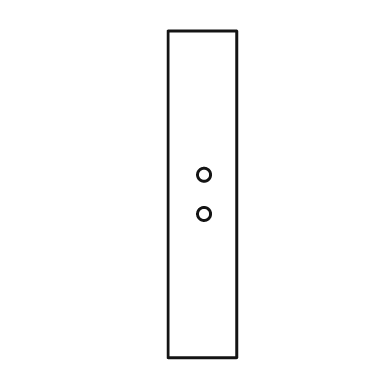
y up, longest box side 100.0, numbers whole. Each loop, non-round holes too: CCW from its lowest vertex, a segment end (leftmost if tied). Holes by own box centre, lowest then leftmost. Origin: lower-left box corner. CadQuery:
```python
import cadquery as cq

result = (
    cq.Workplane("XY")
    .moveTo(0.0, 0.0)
    .lineTo(21.0, 0.0)
    .lineTo(21.0, 100.0)
    .lineTo(0.0, 100.0)
    .close()
    .moveTo(11.0, 44.0)
    .circle(2.0)
    .moveTo(11.0, 56.0)
    .circle(2.0)
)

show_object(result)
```